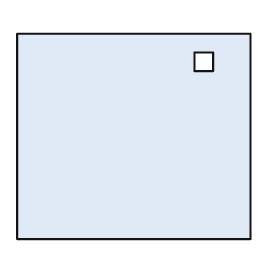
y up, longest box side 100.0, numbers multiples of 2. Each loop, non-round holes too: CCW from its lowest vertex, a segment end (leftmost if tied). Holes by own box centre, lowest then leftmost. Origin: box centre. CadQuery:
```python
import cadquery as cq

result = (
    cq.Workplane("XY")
    .moveTo(-50.0, -44.0)
    .lineTo(50.0, -44.0)
    .lineTo(50.0, 44.0)
    .lineTo(-50.0, 44.0)
    .close()
    .moveTo(26.0, 28.0)
    .lineTo(34.0, 28.0)
    .lineTo(34.0, 36.0)
    .lineTo(26.0, 36.0)
    .close()
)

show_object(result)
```